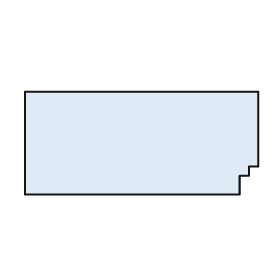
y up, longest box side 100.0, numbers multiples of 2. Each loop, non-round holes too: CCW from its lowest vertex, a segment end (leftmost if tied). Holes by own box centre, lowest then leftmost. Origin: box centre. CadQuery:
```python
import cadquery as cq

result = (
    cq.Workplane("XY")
    .moveTo(-50.0, -22.0)
    .lineTo(42.0, -22.0)
    .lineTo(42.0, -14.0)
    .lineTo(46.0, -14.0)
    .lineTo(46.0, -10.0)
    .lineTo(50.0, -10.0)
    .lineTo(50.0, 22.0)
    .lineTo(-50.0, 22.0)
    .close()
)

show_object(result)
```